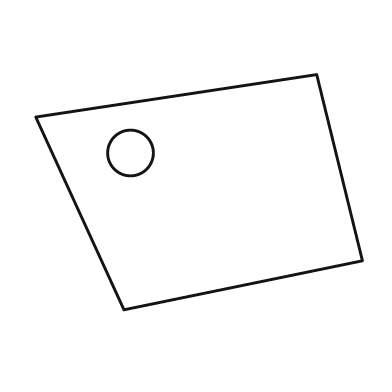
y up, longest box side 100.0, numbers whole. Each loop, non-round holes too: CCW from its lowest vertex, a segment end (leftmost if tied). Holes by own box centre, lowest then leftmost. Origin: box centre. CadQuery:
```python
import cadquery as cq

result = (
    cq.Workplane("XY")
    .moveTo(-23.0, -36.0)
    .lineTo(50.0, -21.0)
    .lineTo(36.0, 36.0)
    .lineTo(-50.0, 23.0)
    .close()
    .moveTo(-21.0, 12.0)
    .circle(7.0)
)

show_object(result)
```